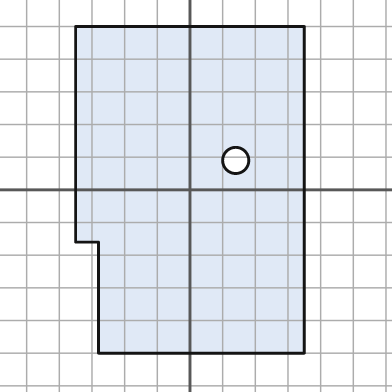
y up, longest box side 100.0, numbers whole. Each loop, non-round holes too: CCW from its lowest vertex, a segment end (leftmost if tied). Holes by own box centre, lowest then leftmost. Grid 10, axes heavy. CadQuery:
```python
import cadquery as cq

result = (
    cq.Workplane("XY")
    .moveTo(-28.0, -50.0)
    .lineTo(35.0, -50.0)
    .lineTo(35.0, 50.0)
    .lineTo(-35.0, 50.0)
    .lineTo(-35.0, -16.0)
    .lineTo(-28.0, -16.0)
    .close()
    .moveTo(14.0, 9.0)
    .circle(4.0)
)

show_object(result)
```